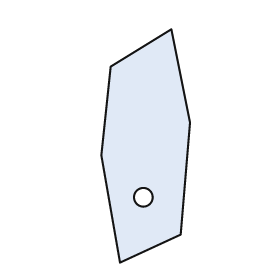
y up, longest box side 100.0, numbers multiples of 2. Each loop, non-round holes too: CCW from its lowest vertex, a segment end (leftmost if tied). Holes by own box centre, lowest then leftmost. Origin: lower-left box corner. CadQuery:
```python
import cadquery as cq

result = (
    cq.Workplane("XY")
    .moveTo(8.0, 0.0)
    .lineTo(34.0, 12.0)
    .lineTo(38.0, 60.0)
    .lineTo(30.0, 100.0)
    .lineTo(4.0, 84.0)
    .lineTo(0.0, 46.0)
    .close()
    .moveTo(18.0, 28.0)
    .circle(4.0)
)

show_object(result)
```